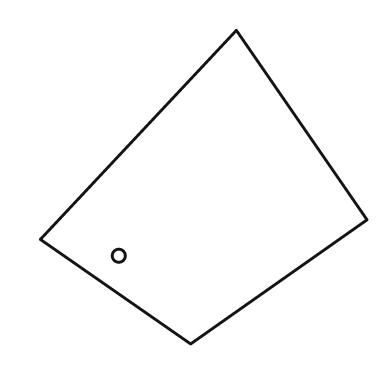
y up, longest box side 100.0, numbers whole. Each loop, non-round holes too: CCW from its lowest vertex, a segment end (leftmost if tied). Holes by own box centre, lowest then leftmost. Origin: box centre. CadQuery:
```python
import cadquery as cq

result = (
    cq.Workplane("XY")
    .moveTo(-4.0, -48.0)
    .lineTo(50.0, -10.0)
    .lineTo(10.0, 48.0)
    .lineTo(-50.0, -16.0)
    .close()
    .moveTo(-26.0, -21.0)
    .circle(2.0)
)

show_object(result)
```